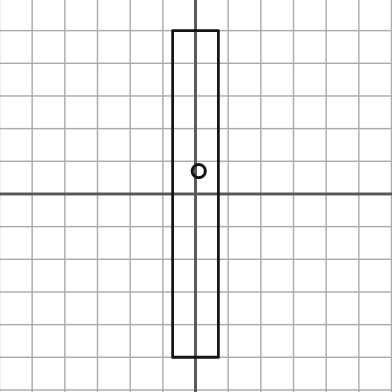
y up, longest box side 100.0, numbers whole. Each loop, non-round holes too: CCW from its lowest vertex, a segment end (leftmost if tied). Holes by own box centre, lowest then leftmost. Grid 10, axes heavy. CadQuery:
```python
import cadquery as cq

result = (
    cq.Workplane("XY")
    .moveTo(-7.0, -50.0)
    .lineTo(7.0, -50.0)
    .lineTo(7.0, 50.0)
    .lineTo(-7.0, 50.0)
    .close()
    .moveTo(1.0, 7.0)
    .circle(2.0)
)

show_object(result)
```